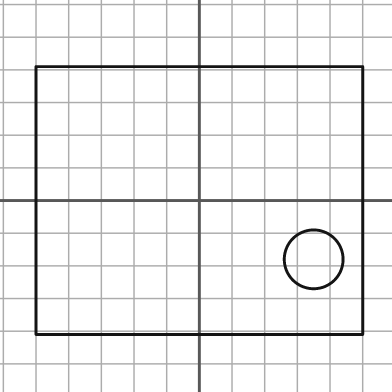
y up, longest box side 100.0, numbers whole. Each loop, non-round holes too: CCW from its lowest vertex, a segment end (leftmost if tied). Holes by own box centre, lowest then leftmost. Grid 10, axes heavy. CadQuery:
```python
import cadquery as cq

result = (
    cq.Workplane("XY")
    .moveTo(-50.0, -41.0)
    .lineTo(50.0, -41.0)
    .lineTo(50.0, 41.0)
    .lineTo(-50.0, 41.0)
    .close()
    .moveTo(35.0, -18.0)
    .circle(9.0)
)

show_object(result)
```